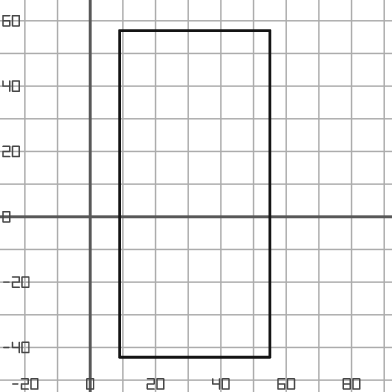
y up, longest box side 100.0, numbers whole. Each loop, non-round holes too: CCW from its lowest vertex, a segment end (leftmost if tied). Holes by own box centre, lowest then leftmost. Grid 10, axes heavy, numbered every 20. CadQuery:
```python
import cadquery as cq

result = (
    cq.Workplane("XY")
    .moveTo(9.0, -43.0)
    .lineTo(55.0, -43.0)
    .lineTo(55.0, 57.0)
    .lineTo(9.0, 57.0)
    .close()
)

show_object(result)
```